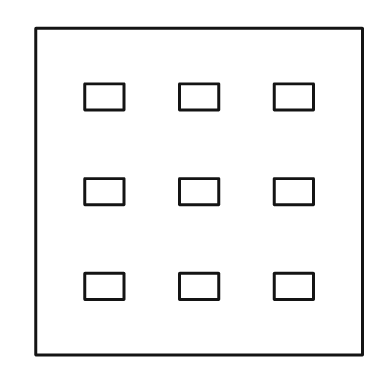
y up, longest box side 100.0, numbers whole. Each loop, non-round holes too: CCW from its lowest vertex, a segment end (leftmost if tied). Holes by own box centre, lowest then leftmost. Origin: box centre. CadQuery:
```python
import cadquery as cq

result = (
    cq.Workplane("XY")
    .moveTo(-50.0, -50.0)
    .lineTo(50.0, -50.0)
    .lineTo(50.0, 50.0)
    .lineTo(-50.0, 50.0)
    .close()
    .moveTo(-35.0, -33.0)
    .lineTo(-23.0, -33.0)
    .lineTo(-23.0, -25.0)
    .lineTo(-35.0, -25.0)
    .close()
    .moveTo(-6.0, -33.0)
    .lineTo(6.0, -33.0)
    .lineTo(6.0, -25.0)
    .lineTo(-6.0, -25.0)
    .close()
    .moveTo(23.0, -33.0)
    .lineTo(35.0, -33.0)
    .lineTo(35.0, -25.0)
    .lineTo(23.0, -25.0)
    .close()
    .moveTo(-35.0, -4.0)
    .lineTo(-23.0, -4.0)
    .lineTo(-23.0, 4.0)
    .lineTo(-35.0, 4.0)
    .close()
    .moveTo(-6.0, -4.0)
    .lineTo(6.0, -4.0)
    .lineTo(6.0, 4.0)
    .lineTo(-6.0, 4.0)
    .close()
    .moveTo(23.0, -4.0)
    .lineTo(35.0, -4.0)
    .lineTo(35.0, 4.0)
    .lineTo(23.0, 4.0)
    .close()
    .moveTo(-35.0, 25.0)
    .lineTo(-23.0, 25.0)
    .lineTo(-23.0, 33.0)
    .lineTo(-35.0, 33.0)
    .close()
    .moveTo(-6.0, 25.0)
    .lineTo(6.0, 25.0)
    .lineTo(6.0, 33.0)
    .lineTo(-6.0, 33.0)
    .close()
    .moveTo(23.0, 25.0)
    .lineTo(35.0, 25.0)
    .lineTo(35.0, 33.0)
    .lineTo(23.0, 33.0)
    .close()
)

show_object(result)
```